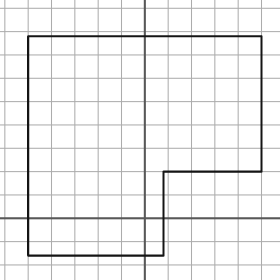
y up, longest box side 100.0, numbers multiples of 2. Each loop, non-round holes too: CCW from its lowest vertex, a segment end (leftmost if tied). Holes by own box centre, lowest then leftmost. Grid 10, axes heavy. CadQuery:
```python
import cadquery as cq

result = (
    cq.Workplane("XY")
    .moveTo(-50.0, -16.0)
    .lineTo(8.0, -16.0)
    .lineTo(8.0, 20.0)
    .lineTo(50.0, 20.0)
    .lineTo(50.0, 78.0)
    .lineTo(-50.0, 78.0)
    .close()
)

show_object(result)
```